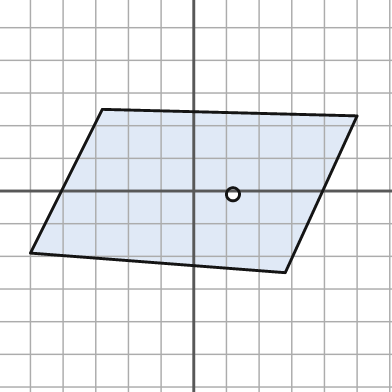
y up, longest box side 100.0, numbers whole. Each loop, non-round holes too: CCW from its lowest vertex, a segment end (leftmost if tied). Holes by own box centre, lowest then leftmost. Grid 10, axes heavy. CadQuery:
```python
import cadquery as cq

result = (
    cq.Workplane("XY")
    .moveTo(28.0, -25.0)
    .lineTo(50.0, 23.0)
    .lineTo(-28.0, 25.0)
    .lineTo(-50.0, -19.0)
    .close()
    .moveTo(12.0, -1.0)
    .circle(2.0)
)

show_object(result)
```